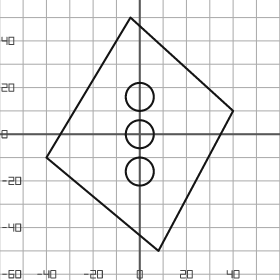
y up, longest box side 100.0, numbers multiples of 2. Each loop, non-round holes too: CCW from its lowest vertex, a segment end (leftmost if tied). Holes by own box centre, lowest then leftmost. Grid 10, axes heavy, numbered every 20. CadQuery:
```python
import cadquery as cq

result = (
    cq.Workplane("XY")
    .moveTo(8.0, -50.0)
    .lineTo(40.0, 10.0)
    .lineTo(-4.0, 50.0)
    .lineTo(-40.0, -10.0)
    .close()
    .moveTo(0.0, -16.0)
    .circle(6.0)
    .moveTo(0.0, 0.0)
    .circle(6.0)
    .moveTo(0.0, 16.0)
    .circle(6.0)
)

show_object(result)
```